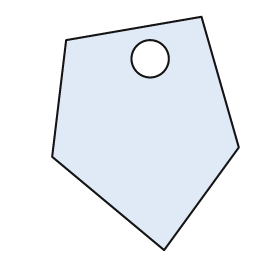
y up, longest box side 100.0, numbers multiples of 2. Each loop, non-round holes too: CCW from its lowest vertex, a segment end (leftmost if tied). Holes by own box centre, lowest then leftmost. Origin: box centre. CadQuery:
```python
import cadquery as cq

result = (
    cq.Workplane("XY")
    .moveTo(8.0, -50.0)
    .lineTo(40.0, -6.0)
    .lineTo(24.0, 50.0)
    .lineTo(-34.0, 40.0)
    .lineTo(-40.0, -10.0)
    .close()
    .moveTo(2.0, 32.0)
    .circle(8.0)
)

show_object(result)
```